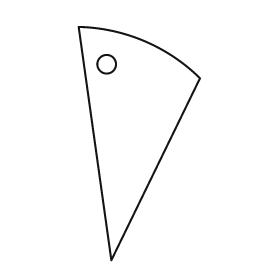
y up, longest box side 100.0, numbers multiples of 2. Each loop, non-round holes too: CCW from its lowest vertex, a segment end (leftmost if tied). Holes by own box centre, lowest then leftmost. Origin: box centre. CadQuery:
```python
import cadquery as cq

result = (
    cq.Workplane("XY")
    .moveTo(-12.0, -50.0)
    .lineTo(26.0, 28.0)
    .threePointArc((2.0, 44.0), (-26.0, 50.0))
    .close()
    .moveTo(-14.0, 34.0)
    .circle(4.0)
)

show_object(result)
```